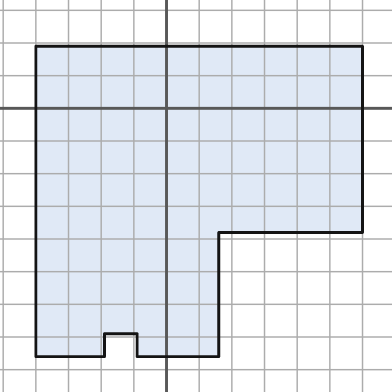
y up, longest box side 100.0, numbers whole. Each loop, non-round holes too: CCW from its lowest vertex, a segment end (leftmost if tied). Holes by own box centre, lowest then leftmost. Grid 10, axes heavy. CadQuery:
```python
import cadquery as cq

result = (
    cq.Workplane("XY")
    .moveTo(-40.0, -76.0)
    .lineTo(-19.0, -76.0)
    .lineTo(-19.0, -69.0)
    .lineTo(-9.0, -69.0)
    .lineTo(-9.0, -76.0)
    .lineTo(16.0, -76.0)
    .lineTo(16.0, -38.0)
    .lineTo(60.0, -38.0)
    .lineTo(60.0, 19.0)
    .lineTo(-40.0, 19.0)
    .close()
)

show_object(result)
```